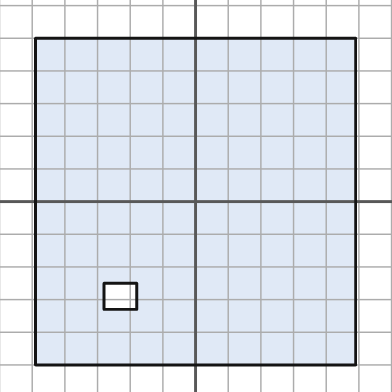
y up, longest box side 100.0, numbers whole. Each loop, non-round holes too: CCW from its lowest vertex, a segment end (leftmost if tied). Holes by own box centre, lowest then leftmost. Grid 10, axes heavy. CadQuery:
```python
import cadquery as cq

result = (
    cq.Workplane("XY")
    .moveTo(-49.0, -50.0)
    .lineTo(49.0, -50.0)
    .lineTo(49.0, 50.0)
    .lineTo(-49.0, 50.0)
    .close()
    .moveTo(-28.0, -33.0)
    .lineTo(-18.0, -33.0)
    .lineTo(-18.0, -25.0)
    .lineTo(-28.0, -25.0)
    .close()
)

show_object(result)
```